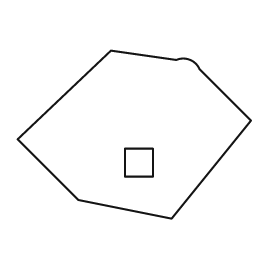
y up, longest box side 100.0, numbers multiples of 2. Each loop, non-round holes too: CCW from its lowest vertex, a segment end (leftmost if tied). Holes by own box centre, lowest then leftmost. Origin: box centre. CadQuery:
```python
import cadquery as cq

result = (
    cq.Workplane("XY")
    .moveTo(16.0, -36.0)
    .lineTo(50.0, 6.0)
    .lineTo(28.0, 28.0)
    .threePointArc((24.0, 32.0), (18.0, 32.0))
    .lineTo(-10.0, 36.0)
    .lineTo(-50.0, -2.0)
    .lineTo(-24.0, -28.0)
    .close()
    .moveTo(-4.0, -18.0)
    .lineTo(8.0, -18.0)
    .lineTo(8.0, -6.0)
    .lineTo(-4.0, -6.0)
    .close()
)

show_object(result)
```